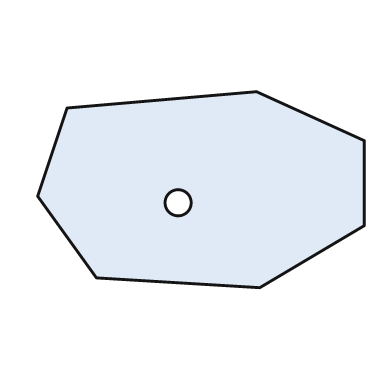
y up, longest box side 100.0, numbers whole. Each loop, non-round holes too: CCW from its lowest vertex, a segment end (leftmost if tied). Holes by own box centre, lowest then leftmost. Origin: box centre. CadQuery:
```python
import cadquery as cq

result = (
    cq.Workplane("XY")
    .moveTo(18.0, -30.0)
    .lineTo(50.0, -11.0)
    .lineTo(50.0, 15.0)
    .lineTo(17.0, 30.0)
    .lineTo(-41.0, 25.0)
    .lineTo(-50.0, -2.0)
    .lineTo(-32.0, -27.0)
    .close()
    .moveTo(-7.0, -4.0)
    .circle(4.0)
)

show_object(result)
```